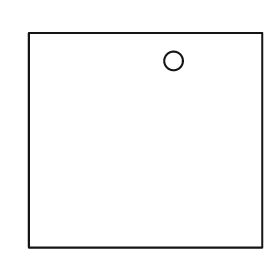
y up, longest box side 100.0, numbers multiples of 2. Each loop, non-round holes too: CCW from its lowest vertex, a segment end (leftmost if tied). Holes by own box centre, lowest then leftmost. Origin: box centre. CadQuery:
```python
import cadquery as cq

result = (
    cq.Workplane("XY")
    .moveTo(-50.0, -46.0)
    .lineTo(50.0, -46.0)
    .lineTo(50.0, 46.0)
    .lineTo(-50.0, 46.0)
    .close()
    .moveTo(12.0, 34.0)
    .circle(4.0)
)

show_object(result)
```